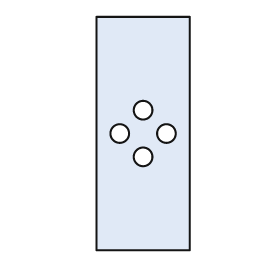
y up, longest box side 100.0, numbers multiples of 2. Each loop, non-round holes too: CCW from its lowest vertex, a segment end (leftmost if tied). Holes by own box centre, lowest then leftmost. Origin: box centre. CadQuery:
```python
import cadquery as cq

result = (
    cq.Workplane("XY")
    .moveTo(-20.0, -50.0)
    .lineTo(20.0, -50.0)
    .lineTo(20.0, 50.0)
    .lineTo(-20.0, 50.0)
    .close()
    .moveTo(0.0, -10.0)
    .circle(4.0)
    .moveTo(-10.0, 0.0)
    .circle(4.0)
    .moveTo(10.0, 0.0)
    .circle(4.0)
    .moveTo(0.0, 10.0)
    .circle(4.0)
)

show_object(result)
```